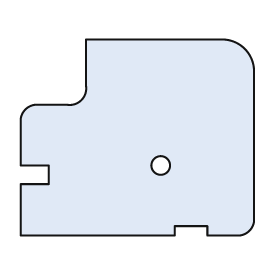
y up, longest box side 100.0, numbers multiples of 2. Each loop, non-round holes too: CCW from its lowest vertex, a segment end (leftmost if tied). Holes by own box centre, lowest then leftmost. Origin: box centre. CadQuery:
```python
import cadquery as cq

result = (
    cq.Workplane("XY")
    .moveTo(-50.0, -42.0)
    .lineTo(16.0, -42.0)
    .lineTo(16.0, -38.0)
    .lineTo(30.0, -38.0)
    .lineTo(30.0, -42.0)
    .lineTo(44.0, -42.0)
    .threePointArc((48.0, -40.0), (50.0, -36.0))
    .lineTo(50.0, 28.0)
    .threePointArc((46.0, 38.0), (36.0, 42.0))
    .lineTo(-22.0, 42.0)
    .lineTo(-22.0, 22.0)
    .threePointArc((-24.0, 16.0), (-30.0, 14.0))
    .lineTo(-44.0, 14.0)
    .threePointArc((-48.0, 12.0), (-50.0, 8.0))
    .lineTo(-50.0, -12.0)
    .lineTo(-38.0, -12.0)
    .lineTo(-38.0, -20.0)
    .lineTo(-50.0, -20.0)
    .close()
    .moveTo(10.0, -12.0)
    .circle(4.0)
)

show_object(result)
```